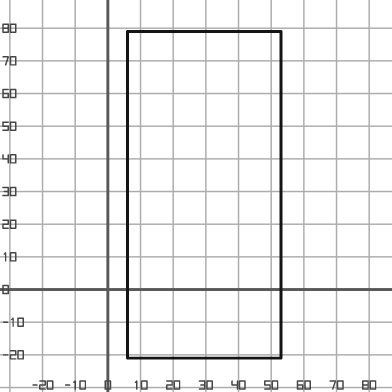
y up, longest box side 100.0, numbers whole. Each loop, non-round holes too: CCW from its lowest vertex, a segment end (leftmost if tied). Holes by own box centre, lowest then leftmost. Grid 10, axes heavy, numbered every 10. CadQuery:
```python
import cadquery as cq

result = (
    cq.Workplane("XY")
    .moveTo(6.0, -21.0)
    .lineTo(53.0, -21.0)
    .lineTo(53.0, 79.0)
    .lineTo(6.0, 79.0)
    .close()
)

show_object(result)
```